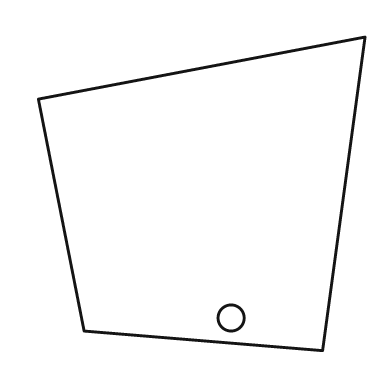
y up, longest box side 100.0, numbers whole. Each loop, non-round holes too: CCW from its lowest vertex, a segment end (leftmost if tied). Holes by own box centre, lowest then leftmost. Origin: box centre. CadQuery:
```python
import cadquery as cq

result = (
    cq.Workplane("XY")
    .moveTo(37.0, -48.0)
    .lineTo(50.0, 48.0)
    .lineTo(-50.0, 29.0)
    .lineTo(-36.0, -42.0)
    .close()
    .moveTo(9.0, -38.0)
    .circle(4.0)
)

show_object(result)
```